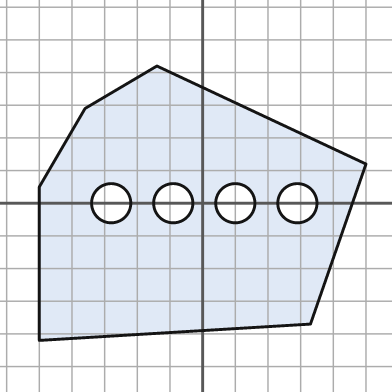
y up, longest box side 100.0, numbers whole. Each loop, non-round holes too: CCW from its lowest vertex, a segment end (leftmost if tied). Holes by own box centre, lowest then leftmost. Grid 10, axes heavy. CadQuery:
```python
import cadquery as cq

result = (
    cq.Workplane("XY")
    .moveTo(-50.0, -42.0)
    .lineTo(33.0, -37.0)
    .lineTo(50.0, 12.0)
    .lineTo(-14.0, 42.0)
    .lineTo(-36.0, 29.0)
    .lineTo(-50.0, 5.0)
    .close()
    .moveTo(-28.0, 0.0)
    .circle(6.0)
    .moveTo(-9.0, 0.0)
    .circle(6.0)
    .moveTo(10.0, 0.0)
    .circle(6.0)
    .moveTo(29.0, 0.0)
    .circle(6.0)
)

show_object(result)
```